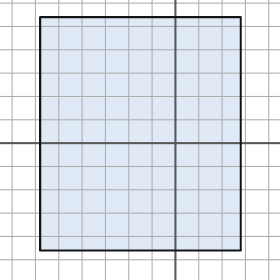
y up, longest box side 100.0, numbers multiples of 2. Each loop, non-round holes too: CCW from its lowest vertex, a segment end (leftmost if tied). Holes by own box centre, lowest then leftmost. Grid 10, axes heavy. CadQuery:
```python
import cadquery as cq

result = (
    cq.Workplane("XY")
    .moveTo(-58.0, -46.0)
    .lineTo(28.0, -46.0)
    .lineTo(28.0, 54.0)
    .lineTo(-58.0, 54.0)
    .close()
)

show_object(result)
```